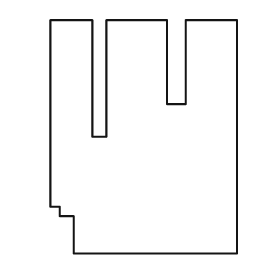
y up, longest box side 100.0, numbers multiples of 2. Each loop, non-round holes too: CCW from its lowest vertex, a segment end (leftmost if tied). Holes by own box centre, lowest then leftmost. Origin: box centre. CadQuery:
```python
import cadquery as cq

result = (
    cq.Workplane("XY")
    .moveTo(-30.0, -50.0)
    .lineTo(40.0, -50.0)
    .lineTo(40.0, 50.0)
    .lineTo(18.0, 50.0)
    .lineTo(18.0, 14.0)
    .lineTo(10.0, 14.0)
    .lineTo(10.0, 50.0)
    .lineTo(-16.0, 50.0)
    .lineTo(-16.0, 0.0)
    .lineTo(-22.0, 0.0)
    .lineTo(-22.0, 50.0)
    .lineTo(-40.0, 50.0)
    .lineTo(-40.0, -30.0)
    .lineTo(-36.0, -30.0)
    .lineTo(-36.0, -34.0)
    .lineTo(-30.0, -34.0)
    .close()
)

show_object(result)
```